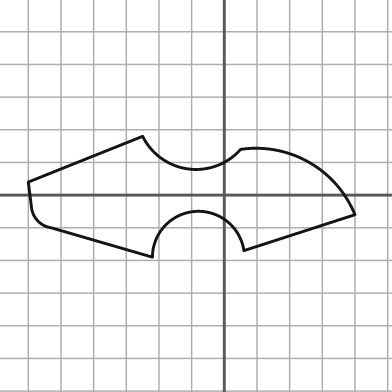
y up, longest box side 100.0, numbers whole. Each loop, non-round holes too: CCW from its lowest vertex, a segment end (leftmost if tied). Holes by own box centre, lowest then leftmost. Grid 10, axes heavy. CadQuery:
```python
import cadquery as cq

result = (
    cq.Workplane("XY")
    .moveTo(-22.0, -19.0)
    .threePointArc((-9.0, -5.0), (6.0, -17.0))
    .lineTo(40.0, -6.0)
    .threePointArc((26.0, 10.0), (5.0, 14.0))
    .threePointArc((-11.0, 8.0), (-25.0, 18.0))
    .lineTo(-60.0, 4.0)
    .lineTo(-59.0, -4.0)
    .threePointArc((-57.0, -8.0), (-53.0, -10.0))
    .close()
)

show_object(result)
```